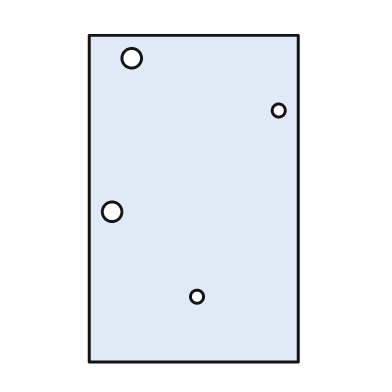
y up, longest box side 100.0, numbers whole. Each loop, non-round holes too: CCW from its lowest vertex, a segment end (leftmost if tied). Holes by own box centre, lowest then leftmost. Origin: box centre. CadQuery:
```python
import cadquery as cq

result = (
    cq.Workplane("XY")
    .moveTo(-32.0, -50.0)
    .lineTo(32.0, -50.0)
    .lineTo(32.0, 50.0)
    .lineTo(-32.0, 50.0)
    .close()
    .moveTo(1.0, -30.0)
    .circle(2.0)
    .moveTo(-25.0, -4.0)
    .circle(3.0)
    .moveTo(26.0, 27.0)
    .circle(2.0)
    .moveTo(-19.0, 43.0)
    .circle(3.0)
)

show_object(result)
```